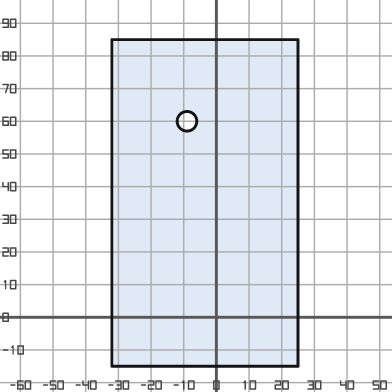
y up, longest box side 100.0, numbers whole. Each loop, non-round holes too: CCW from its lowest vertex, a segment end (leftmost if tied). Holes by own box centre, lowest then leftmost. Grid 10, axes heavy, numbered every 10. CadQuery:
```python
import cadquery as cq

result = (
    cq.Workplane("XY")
    .moveTo(-32.0, -15.0)
    .lineTo(25.0, -15.0)
    .lineTo(25.0, 85.0)
    .lineTo(-32.0, 85.0)
    .close()
    .moveTo(-9.0, 60.0)
    .circle(3.0)
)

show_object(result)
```